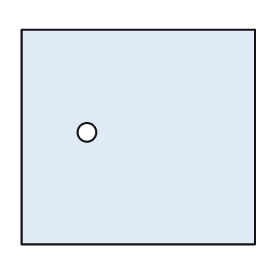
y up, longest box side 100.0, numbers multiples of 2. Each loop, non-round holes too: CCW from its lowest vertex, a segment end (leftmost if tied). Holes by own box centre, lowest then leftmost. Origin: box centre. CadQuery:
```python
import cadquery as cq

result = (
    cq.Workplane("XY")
    .moveTo(-50.0, -46.0)
    .lineTo(50.0, -46.0)
    .lineTo(50.0, 46.0)
    .lineTo(-50.0, 46.0)
    .close()
    .moveTo(-22.0, 2.0)
    .circle(4.0)
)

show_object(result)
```